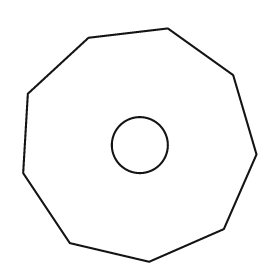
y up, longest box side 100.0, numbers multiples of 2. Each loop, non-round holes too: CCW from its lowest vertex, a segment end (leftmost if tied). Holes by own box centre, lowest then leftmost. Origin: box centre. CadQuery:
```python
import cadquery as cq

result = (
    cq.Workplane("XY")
    .moveTo(4.0, -50.0)
    .lineTo(36.0, -36.0)
    .lineTo(50.0, -4.0)
    .lineTo(40.0, 30.0)
    .lineTo(12.0, 50.0)
    .lineTo(-22.0, 46.0)
    .lineTo(-48.0, 22.0)
    .lineTo(-50.0, -12.0)
    .lineTo(-30.0, -42.0)
    .close()
    .moveTo(0.0, 0.0)
    .circle(12.0)
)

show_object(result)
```